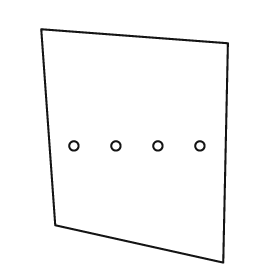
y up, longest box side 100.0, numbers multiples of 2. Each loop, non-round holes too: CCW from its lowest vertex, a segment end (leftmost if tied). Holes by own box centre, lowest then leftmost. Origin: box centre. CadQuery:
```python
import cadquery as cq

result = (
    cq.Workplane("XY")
    .moveTo(38.0, -50.0)
    .lineTo(40.0, 44.0)
    .lineTo(-40.0, 50.0)
    .lineTo(-34.0, -34.0)
    .close()
    .moveTo(-26.0, 0.0)
    .circle(2.0)
    .moveTo(-8.0, 0.0)
    .circle(2.0)
    .moveTo(10.0, 0.0)
    .circle(2.0)
    .moveTo(28.0, 0.0)
    .circle(2.0)
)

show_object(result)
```